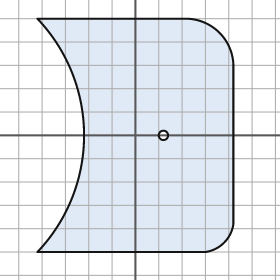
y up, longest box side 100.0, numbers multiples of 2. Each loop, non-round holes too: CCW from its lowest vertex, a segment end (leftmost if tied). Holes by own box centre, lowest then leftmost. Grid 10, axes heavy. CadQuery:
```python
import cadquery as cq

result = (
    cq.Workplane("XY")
    .moveTo(-42.0, -50.0)
    .lineTo(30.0, -50.0)
    .threePointArc((38.0, -46.0), (42.0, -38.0))
    .lineTo(42.0, 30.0)
    .threePointArc((36.0, 44.0), (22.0, 50.0))
    .lineTo(-42.0, 50.0)
    .threePointArc((-22.0, 0.0), (-42.0, -50.0))
    .close()
    .moveTo(12.0, 0.0)
    .circle(2.0)
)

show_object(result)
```